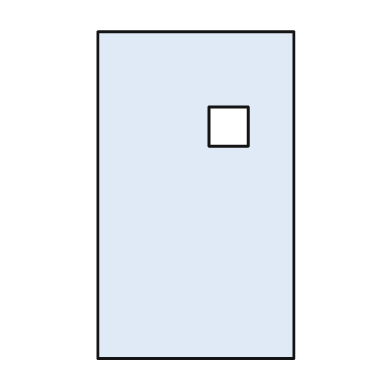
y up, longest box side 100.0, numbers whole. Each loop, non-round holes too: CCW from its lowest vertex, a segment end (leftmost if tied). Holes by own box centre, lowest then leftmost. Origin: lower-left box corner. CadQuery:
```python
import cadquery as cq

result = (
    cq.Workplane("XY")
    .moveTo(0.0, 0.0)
    .lineTo(60.0, 0.0)
    .lineTo(60.0, 100.0)
    .lineTo(0.0, 100.0)
    .close()
    .moveTo(34.0, 65.0)
    .lineTo(46.0, 65.0)
    .lineTo(46.0, 77.0)
    .lineTo(34.0, 77.0)
    .close()
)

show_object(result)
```